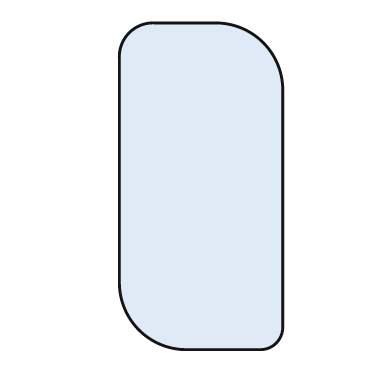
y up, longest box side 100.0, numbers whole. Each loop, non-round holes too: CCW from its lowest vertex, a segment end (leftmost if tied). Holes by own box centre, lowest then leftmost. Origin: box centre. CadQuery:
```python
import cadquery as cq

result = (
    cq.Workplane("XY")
    .moveTo(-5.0, -50.0)
    .lineTo(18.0, -50.0)
    .threePointArc((23.0, -48.0), (25.0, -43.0))
    .lineTo(25.0, 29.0)
    .threePointArc((19.0, 44.0), (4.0, 50.0))
    .lineTo(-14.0, 50.0)
    .threePointArc((-22.0, 47.0), (-25.0, 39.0))
    .lineTo(-25.0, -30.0)
    .threePointArc((-19.0, -44.0), (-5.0, -50.0))
    .close()
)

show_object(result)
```